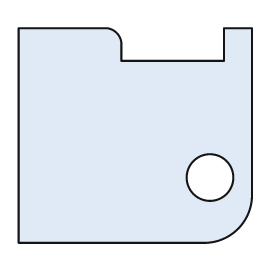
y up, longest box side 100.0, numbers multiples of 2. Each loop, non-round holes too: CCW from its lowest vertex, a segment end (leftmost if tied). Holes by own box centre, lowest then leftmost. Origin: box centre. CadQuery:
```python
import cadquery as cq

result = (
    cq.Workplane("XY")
    .moveTo(-50.0, -46.0)
    .lineTo(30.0, -46.0)
    .threePointArc((44.0, -40.0), (50.0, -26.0))
    .lineTo(50.0, 46.0)
    .lineTo(38.0, 46.0)
    .lineTo(38.0, 32.0)
    .lineTo(-6.0, 32.0)
    .lineTo(-6.0, 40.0)
    .threePointArc((-8.0, 44.0), (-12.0, 46.0))
    .lineTo(-50.0, 46.0)
    .close()
    .moveTo(32.0, -18.0)
    .circle(10.0)
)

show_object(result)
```